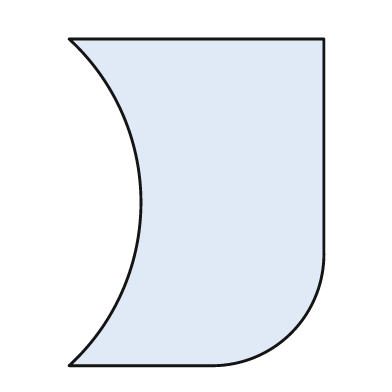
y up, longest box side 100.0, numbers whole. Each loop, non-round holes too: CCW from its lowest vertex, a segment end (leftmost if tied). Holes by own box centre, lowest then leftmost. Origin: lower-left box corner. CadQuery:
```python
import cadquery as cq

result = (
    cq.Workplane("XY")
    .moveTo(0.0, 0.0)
    .lineTo(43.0, 0.0)
    .threePointArc((68.0, 10.0), (78.0, 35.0))
    .lineTo(78.0, 100.0)
    .lineTo(0.0, 100.0)
    .threePointArc((22.0, 50.0), (0.0, 0.0))
    .close()
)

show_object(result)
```